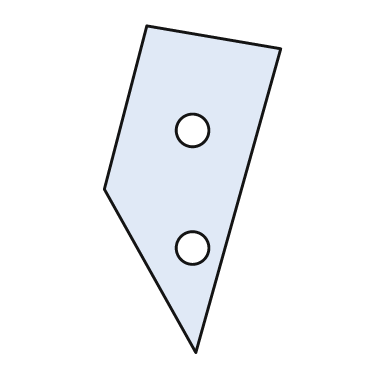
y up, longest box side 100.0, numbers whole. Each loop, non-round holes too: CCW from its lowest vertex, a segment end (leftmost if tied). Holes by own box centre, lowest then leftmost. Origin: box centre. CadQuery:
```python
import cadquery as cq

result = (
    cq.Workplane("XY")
    .moveTo(1.0, -50.0)
    .lineTo(27.0, 43.0)
    .lineTo(-14.0, 50.0)
    .lineTo(-27.0, 0.0)
    .close()
    .moveTo(0.0, -18.0)
    .circle(5.0)
    .moveTo(0.0, 18.0)
    .circle(5.0)
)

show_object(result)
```